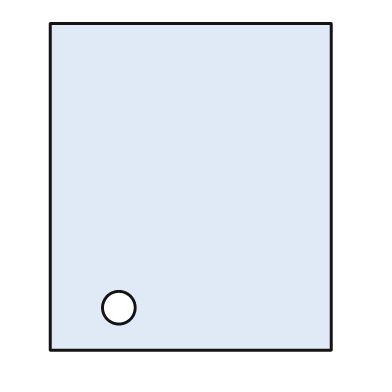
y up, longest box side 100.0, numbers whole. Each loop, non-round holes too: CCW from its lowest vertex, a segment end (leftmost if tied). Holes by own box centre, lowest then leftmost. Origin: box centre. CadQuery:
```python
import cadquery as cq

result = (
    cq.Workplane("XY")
    .moveTo(-43.0, -50.0)
    .lineTo(43.0, -50.0)
    .lineTo(43.0, 50.0)
    .lineTo(-43.0, 50.0)
    .close()
    .moveTo(-22.0, -37.0)
    .circle(5.0)
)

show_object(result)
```